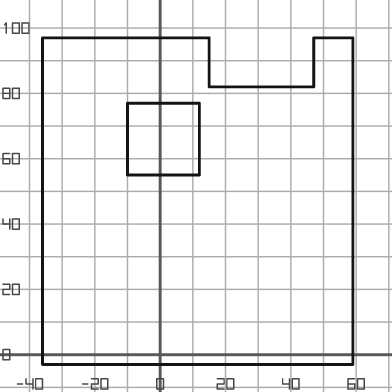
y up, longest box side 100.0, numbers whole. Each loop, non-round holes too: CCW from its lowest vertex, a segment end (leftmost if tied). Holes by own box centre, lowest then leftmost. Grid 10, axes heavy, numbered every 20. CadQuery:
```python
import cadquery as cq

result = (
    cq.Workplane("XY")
    .moveTo(-36.0, -3.0)
    .lineTo(59.0, -3.0)
    .lineTo(59.0, 97.0)
    .lineTo(47.0, 97.0)
    .lineTo(47.0, 82.0)
    .lineTo(15.0, 82.0)
    .lineTo(15.0, 97.0)
    .lineTo(-36.0, 97.0)
    .close()
    .moveTo(-10.0, 55.0)
    .lineTo(12.0, 55.0)
    .lineTo(12.0, 77.0)
    .lineTo(-10.0, 77.0)
    .close()
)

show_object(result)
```